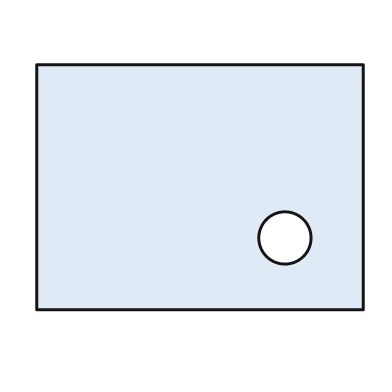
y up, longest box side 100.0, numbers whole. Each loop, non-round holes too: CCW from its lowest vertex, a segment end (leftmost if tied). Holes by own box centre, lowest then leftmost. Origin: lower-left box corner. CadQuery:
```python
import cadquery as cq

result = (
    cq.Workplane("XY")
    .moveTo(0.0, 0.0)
    .lineTo(100.0, 0.0)
    .lineTo(100.0, 75.0)
    .lineTo(0.0, 75.0)
    .close()
    .moveTo(76.0, 22.0)
    .circle(8.0)
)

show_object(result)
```